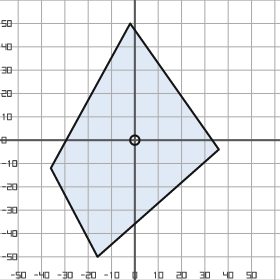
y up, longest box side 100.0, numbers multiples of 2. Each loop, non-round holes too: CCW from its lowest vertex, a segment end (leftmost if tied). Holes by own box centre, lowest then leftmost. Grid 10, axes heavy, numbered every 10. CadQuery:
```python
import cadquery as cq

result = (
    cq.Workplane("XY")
    .moveTo(-16.0, -50.0)
    .lineTo(36.0, -4.0)
    .lineTo(-2.0, 50.0)
    .lineTo(-36.0, -12.0)
    .close()
    .moveTo(0.0, 0.0)
    .circle(2.0)
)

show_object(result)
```